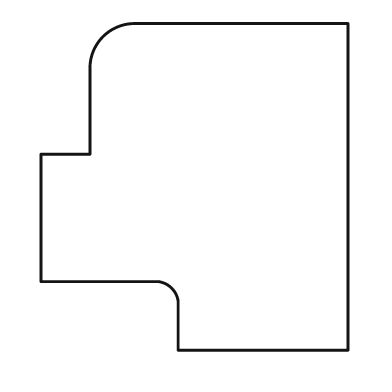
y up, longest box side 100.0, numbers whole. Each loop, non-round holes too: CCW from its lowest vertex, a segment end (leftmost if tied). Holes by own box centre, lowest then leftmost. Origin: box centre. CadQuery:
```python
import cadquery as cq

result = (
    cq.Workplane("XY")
    .moveTo(-5.0, -50.0)
    .lineTo(47.0, -50.0)
    .lineTo(47.0, 50.0)
    .lineTo(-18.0, 50.0)
    .threePointArc((-28.0, 46.0), (-32.0, 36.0))
    .lineTo(-32.0, 10.0)
    .lineTo(-47.0, 10.0)
    .lineTo(-47.0, -29.0)
    .lineTo(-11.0, -29.0)
    .threePointArc((-7.0, -31.0), (-5.0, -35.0))
    .close()
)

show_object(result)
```